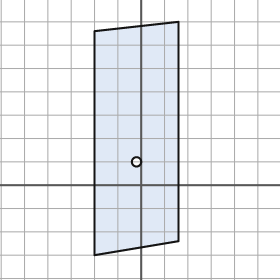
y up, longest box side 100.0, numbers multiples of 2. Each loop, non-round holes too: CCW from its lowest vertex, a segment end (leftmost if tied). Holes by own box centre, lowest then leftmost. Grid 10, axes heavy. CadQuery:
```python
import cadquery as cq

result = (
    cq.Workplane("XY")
    .moveTo(-20.0, -30.0)
    .lineTo(16.0, -24.0)
    .lineTo(16.0, 70.0)
    .lineTo(-20.0, 66.0)
    .close()
    .moveTo(-2.0, 10.0)
    .circle(2.0)
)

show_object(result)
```